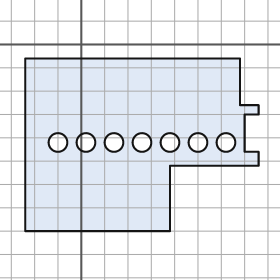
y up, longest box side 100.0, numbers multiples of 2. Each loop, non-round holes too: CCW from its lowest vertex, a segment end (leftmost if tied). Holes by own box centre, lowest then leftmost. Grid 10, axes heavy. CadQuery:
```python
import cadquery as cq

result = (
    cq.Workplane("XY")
    .moveTo(-24.0, -80.0)
    .lineTo(38.0, -80.0)
    .lineTo(38.0, -52.0)
    .lineTo(76.0, -52.0)
    .lineTo(76.0, -46.0)
    .lineTo(70.0, -46.0)
    .lineTo(70.0, -30.0)
    .lineTo(76.0, -30.0)
    .lineTo(76.0, -26.0)
    .lineTo(68.0, -26.0)
    .lineTo(68.0, -6.0)
    .lineTo(-24.0, -6.0)
    .close()
    .moveTo(-10.0, -42.0)
    .circle(4.0)
    .moveTo(2.0, -42.0)
    .circle(4.0)
    .moveTo(14.0, -42.0)
    .circle(4.0)
    .moveTo(26.0, -42.0)
    .circle(4.0)
    .moveTo(38.0, -42.0)
    .circle(4.0)
    .moveTo(50.0, -42.0)
    .circle(4.0)
    .moveTo(62.0, -42.0)
    .circle(4.0)
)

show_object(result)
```